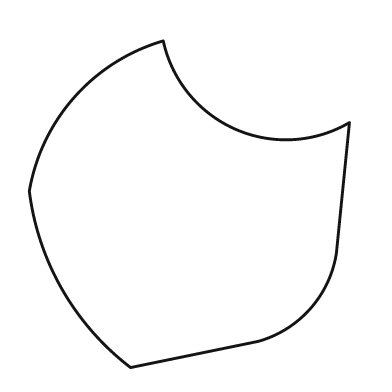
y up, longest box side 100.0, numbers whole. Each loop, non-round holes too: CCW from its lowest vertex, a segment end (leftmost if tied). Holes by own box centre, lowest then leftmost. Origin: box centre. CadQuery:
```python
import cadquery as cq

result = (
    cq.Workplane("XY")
    .moveTo(-18.0, -50.0)
    .lineTo(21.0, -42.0)
    .threePointArc((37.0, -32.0), (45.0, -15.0))
    .lineTo(49.0, 25.0)
    .threePointArc((14.0, 23.0), (-8.0, 50.0))
    .threePointArc((-35.0, 33.0), (-49.0, 4.0))
    .threePointArc((-39.0, -26.0), (-18.0, -50.0))
    .close()
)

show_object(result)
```